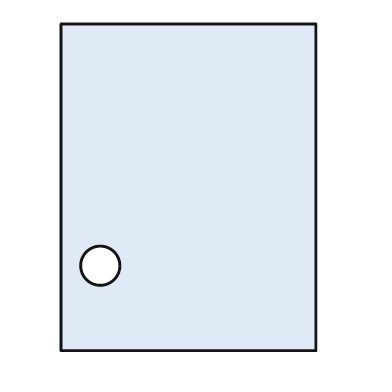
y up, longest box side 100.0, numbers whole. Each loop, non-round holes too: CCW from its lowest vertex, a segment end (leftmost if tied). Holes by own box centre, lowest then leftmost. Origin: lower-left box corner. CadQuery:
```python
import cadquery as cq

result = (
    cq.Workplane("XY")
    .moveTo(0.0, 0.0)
    .lineTo(78.0, 0.0)
    .lineTo(78.0, 100.0)
    .lineTo(0.0, 100.0)
    .close()
    .moveTo(12.0, 26.0)
    .circle(6.0)
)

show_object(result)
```